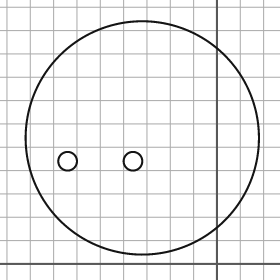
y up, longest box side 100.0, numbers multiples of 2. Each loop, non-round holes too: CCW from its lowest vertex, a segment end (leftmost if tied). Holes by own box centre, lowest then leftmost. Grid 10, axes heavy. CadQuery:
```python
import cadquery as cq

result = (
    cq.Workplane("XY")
    .moveTo(-32.0, 54.0)
    .circle(50.0)
    .moveTo(-64.0, 44.0)
    .circle(4.0)
    .moveTo(-36.0, 44.0)
    .circle(4.0)
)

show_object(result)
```